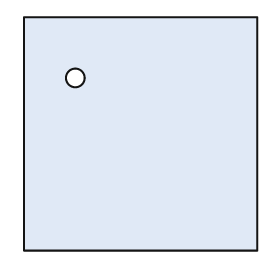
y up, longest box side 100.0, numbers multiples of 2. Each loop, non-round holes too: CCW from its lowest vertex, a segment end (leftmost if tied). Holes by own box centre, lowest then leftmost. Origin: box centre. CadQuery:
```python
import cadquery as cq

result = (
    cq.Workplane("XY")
    .moveTo(-50.0, -50.0)
    .lineTo(50.0, -50.0)
    .lineTo(50.0, 50.0)
    .lineTo(-50.0, 50.0)
    .close()
    .moveTo(-28.0, 24.0)
    .circle(4.0)
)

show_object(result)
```